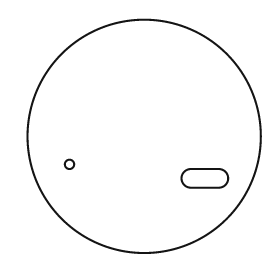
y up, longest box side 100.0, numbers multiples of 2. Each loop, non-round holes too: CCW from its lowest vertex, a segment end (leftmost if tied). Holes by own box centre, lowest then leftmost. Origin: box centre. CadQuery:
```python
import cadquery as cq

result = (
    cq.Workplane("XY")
    .moveTo(0.0, 0.0)
    .circle(50.0)
    .moveTo(20.0, -22.0)
    .lineTo(32.0, -22.0)
    .threePointArc((36.0, -18.0), (32.0, -14.0))
    .lineTo(20.0, -14.0)
    .threePointArc((16.0, -18.0), (20.0, -22.0))
    .close()
    .moveTo(-32.0, -12.0)
    .circle(2.0)
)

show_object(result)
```